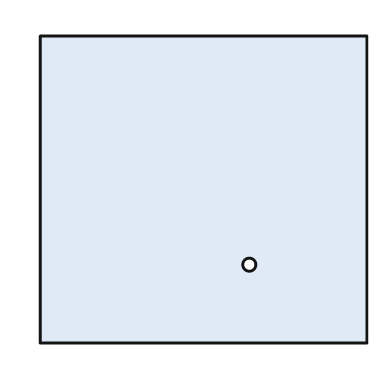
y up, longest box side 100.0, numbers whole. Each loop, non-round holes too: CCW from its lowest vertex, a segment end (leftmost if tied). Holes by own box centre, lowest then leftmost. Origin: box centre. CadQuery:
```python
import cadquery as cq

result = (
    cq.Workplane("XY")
    .moveTo(-50.0, -47.0)
    .lineTo(50.0, -47.0)
    .lineTo(50.0, 47.0)
    .lineTo(-50.0, 47.0)
    .close()
    .moveTo(14.0, -23.0)
    .circle(2.0)
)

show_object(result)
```